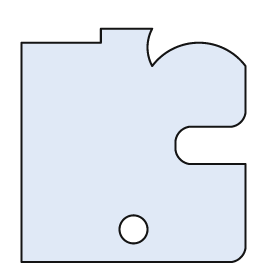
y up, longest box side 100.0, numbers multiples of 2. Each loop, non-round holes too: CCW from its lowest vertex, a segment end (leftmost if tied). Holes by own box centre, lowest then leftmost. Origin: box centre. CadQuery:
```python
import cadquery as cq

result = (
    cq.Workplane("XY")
    .moveTo(-48.0, -50.0)
    .lineTo(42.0, -50.0)
    .threePointArc((46.0, -48.0), (48.0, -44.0))
    .lineTo(48.0, -8.0)
    .lineTo(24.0, -8.0)
    .threePointArc((20.0, -6.0), (18.0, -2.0))
    .lineTo(18.0, 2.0)
    .threePointArc((20.0, 6.0), (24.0, 8.0))
    .lineTo(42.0, 8.0)
    .threePointArc((46.0, 10.0), (48.0, 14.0))
    .lineTo(48.0, 34.0)
    .threePointArc((28.0, 44.0), (8.0, 34.0))
    .threePointArc((6.0, 42.0), (8.0, 50.0))
    .lineTo(-14.0, 50.0)
    .lineTo(-14.0, 44.0)
    .lineTo(-48.0, 44.0)
    .close()
    .moveTo(0.0, -36.0)
    .circle(6.0)
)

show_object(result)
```